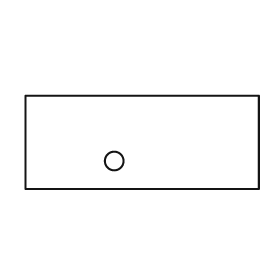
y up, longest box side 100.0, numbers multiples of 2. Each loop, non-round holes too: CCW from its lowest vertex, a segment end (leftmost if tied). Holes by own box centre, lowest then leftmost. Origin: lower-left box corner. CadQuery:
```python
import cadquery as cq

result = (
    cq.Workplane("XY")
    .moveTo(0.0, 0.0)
    .lineTo(100.0, 0.0)
    .lineTo(100.0, 40.0)
    .lineTo(0.0, 40.0)
    .close()
    .moveTo(38.0, 12.0)
    .circle(4.0)
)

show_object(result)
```